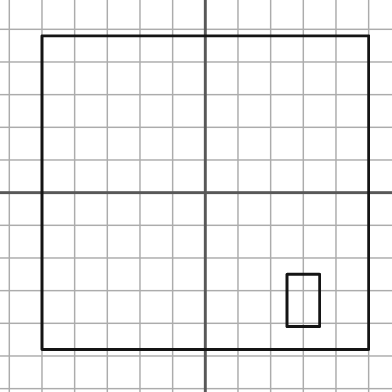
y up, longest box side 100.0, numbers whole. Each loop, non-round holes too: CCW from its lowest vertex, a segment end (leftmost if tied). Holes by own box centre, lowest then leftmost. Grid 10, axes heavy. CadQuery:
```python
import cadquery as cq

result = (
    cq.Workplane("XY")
    .moveTo(-50.0, -48.0)
    .lineTo(50.0, -48.0)
    .lineTo(50.0, 48.0)
    .lineTo(-50.0, 48.0)
    .close()
    .moveTo(25.0, -41.0)
    .lineTo(35.0, -41.0)
    .lineTo(35.0, -25.0)
    .lineTo(25.0, -25.0)
    .close()
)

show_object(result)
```